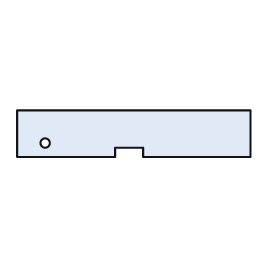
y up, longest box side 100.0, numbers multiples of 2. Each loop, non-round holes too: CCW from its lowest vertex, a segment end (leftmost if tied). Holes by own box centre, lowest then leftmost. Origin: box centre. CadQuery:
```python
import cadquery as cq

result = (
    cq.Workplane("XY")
    .moveTo(-50.0, -10.0)
    .lineTo(-8.0, -10.0)
    .lineTo(-8.0, -6.0)
    .lineTo(4.0, -6.0)
    .lineTo(4.0, -10.0)
    .lineTo(50.0, -10.0)
    .lineTo(50.0, 10.0)
    .lineTo(-50.0, 10.0)
    .close()
    .moveTo(-38.0, -4.0)
    .circle(2.0)
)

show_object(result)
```